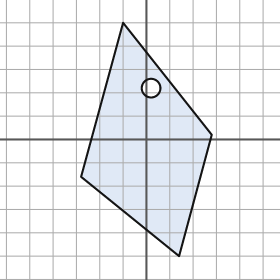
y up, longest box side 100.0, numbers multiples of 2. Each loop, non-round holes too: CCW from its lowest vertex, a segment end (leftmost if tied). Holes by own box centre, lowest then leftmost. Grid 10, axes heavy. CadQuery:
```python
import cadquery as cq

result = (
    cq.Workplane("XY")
    .moveTo(14.0, -50.0)
    .lineTo(28.0, 2.0)
    .lineTo(-10.0, 50.0)
    .lineTo(-28.0, -16.0)
    .close()
    .moveTo(2.0, 22.0)
    .circle(4.0)
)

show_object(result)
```